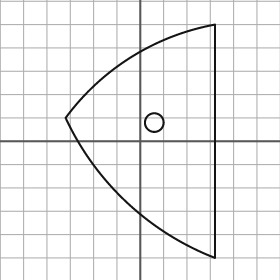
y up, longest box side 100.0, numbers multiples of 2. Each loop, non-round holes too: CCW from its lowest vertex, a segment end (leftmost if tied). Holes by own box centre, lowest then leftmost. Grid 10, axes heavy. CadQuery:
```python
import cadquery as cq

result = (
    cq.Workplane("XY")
    .moveTo(32.0, -50.0)
    .lineTo(32.0, 50.0)
    .threePointArc((-4.0, 36.0), (-32.0, 10.0))
    .threePointArc((-6.0, -26.0), (32.0, -50.0))
    .close()
    .moveTo(6.0, 8.0)
    .circle(4.0)
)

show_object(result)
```